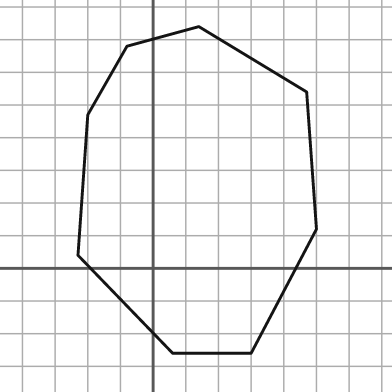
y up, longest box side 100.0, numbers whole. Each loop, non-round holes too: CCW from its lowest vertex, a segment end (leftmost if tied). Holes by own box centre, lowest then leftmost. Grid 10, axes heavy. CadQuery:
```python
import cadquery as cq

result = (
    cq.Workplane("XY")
    .moveTo(6.0, -26.0)
    .lineTo(30.0, -26.0)
    .lineTo(50.0, 12.0)
    .lineTo(47.0, 54.0)
    .lineTo(14.0, 74.0)
    .lineTo(-8.0, 68.0)
    .lineTo(-20.0, 47.0)
    .lineTo(-23.0, 4.0)
    .close()
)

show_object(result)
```